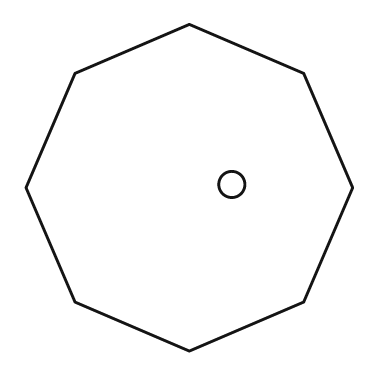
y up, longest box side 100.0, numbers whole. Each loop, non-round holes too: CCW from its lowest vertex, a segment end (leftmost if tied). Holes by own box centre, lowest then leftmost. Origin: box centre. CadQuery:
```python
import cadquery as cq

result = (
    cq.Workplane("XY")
    .moveTo(0.0, -50.0)
    .lineTo(35.0, -35.0)
    .lineTo(50.0, 0.0)
    .lineTo(35.0, 35.0)
    .lineTo(0.0, 50.0)
    .lineTo(-35.0, 35.0)
    .lineTo(-50.0, 0.0)
    .lineTo(-35.0, -35.0)
    .close()
    .moveTo(13.0, 1.0)
    .circle(4.0)
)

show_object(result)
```